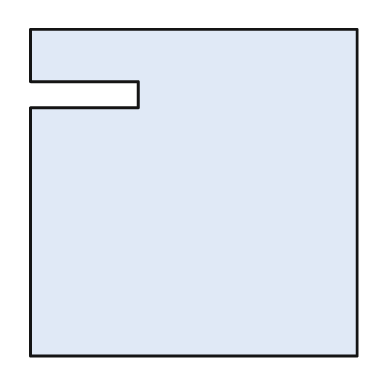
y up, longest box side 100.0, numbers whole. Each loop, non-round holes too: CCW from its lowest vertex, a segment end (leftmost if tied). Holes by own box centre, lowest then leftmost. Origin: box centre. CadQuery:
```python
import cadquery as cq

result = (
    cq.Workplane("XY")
    .moveTo(-50.0, -50.0)
    .lineTo(50.0, -50.0)
    .lineTo(50.0, 50.0)
    .lineTo(-50.0, 50.0)
    .lineTo(-50.0, 34.0)
    .lineTo(-17.0, 34.0)
    .lineTo(-17.0, 26.0)
    .lineTo(-50.0, 26.0)
    .close()
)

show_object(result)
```